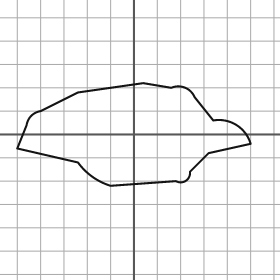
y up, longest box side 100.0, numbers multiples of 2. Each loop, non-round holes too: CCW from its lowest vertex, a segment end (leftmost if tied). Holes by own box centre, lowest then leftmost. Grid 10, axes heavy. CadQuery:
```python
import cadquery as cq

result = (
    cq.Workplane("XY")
    .moveTo(-10.0, -22.0)
    .lineTo(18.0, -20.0)
    .threePointArc((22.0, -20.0), (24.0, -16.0))
    .lineTo(32.0, -8.0)
    .lineTo(50.0, -4.0)
    .threePointArc((44.0, 4.0), (34.0, 6.0))
    .lineTo(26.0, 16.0)
    .threePointArc((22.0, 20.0), (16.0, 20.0))
    .lineTo(4.0, 22.0)
    .lineTo(-24.0, 18.0)
    .lineTo(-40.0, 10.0)
    .threePointArc((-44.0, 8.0), (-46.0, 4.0))
    .lineTo(-50.0, -6.0)
    .lineTo(-24.0, -12.0)
    .threePointArc((-18.0, -18.0), (-10.0, -22.0))
    .close()
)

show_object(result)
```